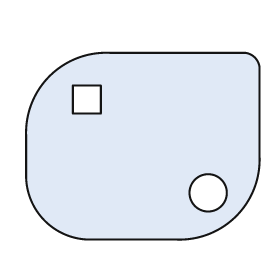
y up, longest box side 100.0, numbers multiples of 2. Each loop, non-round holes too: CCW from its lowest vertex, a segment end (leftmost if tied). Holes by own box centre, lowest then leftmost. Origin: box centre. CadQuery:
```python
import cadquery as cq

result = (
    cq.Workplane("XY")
    .moveTo(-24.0, -40.0)
    .lineTo(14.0, -40.0)
    .threePointArc((40.0, -30.0), (50.0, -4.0))
    .lineTo(50.0, 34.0)
    .threePointArc((48.0, 38.0), (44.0, 40.0))
    .lineTo(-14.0, 40.0)
    .threePointArc((-40.0, 30.0), (-50.0, 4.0))
    .lineTo(-50.0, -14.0)
    .threePointArc((-42.0, -32.0), (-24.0, -40.0))
    .close()
    .moveTo(28.0, -20.0)
    .circle(8.0)
    .moveTo(-30.0, 14.0)
    .lineTo(-18.0, 14.0)
    .lineTo(-18.0, 26.0)
    .lineTo(-30.0, 26.0)
    .close()
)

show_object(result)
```